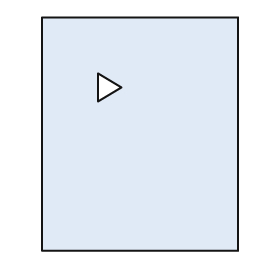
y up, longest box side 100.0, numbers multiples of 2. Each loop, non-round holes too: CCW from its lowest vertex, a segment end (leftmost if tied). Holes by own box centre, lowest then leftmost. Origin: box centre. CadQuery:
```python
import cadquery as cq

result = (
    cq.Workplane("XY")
    .moveTo(-42.0, -50.0)
    .lineTo(42.0, -50.0)
    .lineTo(42.0, 50.0)
    .lineTo(-42.0, 50.0)
    .close()
    .moveTo(-18.0, 14.0)
    .lineTo(-8.0, 20.0)
    .lineTo(-18.0, 26.0)
    .close()
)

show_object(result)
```